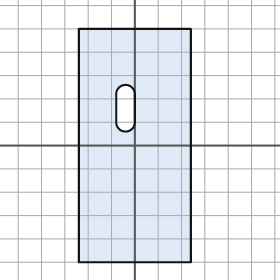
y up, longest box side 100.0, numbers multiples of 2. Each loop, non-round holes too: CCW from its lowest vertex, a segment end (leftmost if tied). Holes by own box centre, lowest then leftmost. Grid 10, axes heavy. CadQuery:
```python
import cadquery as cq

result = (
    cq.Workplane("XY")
    .moveTo(-24.0, -50.0)
    .lineTo(24.0, -50.0)
    .lineTo(24.0, 50.0)
    .lineTo(-24.0, 50.0)
    .close()
    .moveTo(-8.0, 10.0)
    .threePointArc((-4.0, 6.0), (0.0, 10.0))
    .lineTo(0.0, 22.0)
    .threePointArc((-4.0, 26.0), (-8.0, 22.0))
    .close()
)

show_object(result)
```